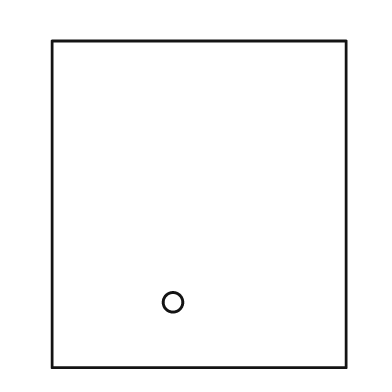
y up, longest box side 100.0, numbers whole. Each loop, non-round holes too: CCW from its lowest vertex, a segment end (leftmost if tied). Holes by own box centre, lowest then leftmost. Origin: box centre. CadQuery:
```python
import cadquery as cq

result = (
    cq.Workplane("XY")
    .moveTo(-45.0, -50.0)
    .lineTo(45.0, -50.0)
    .lineTo(45.0, 50.0)
    .lineTo(-45.0, 50.0)
    .close()
    .moveTo(-8.0, -30.0)
    .circle(3.0)
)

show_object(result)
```